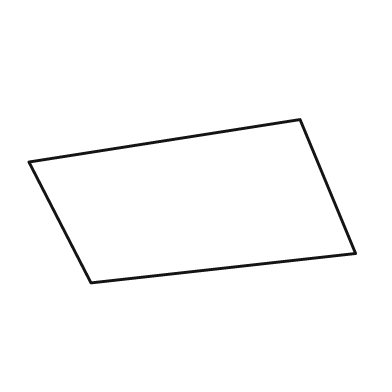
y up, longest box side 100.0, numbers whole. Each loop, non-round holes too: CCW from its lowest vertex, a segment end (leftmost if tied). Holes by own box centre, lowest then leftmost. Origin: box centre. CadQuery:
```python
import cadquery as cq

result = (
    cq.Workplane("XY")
    .moveTo(-31.0, -25.0)
    .lineTo(50.0, -16.0)
    .lineTo(33.0, 25.0)
    .lineTo(-50.0, 12.0)
    .close()
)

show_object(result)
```